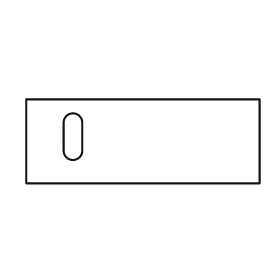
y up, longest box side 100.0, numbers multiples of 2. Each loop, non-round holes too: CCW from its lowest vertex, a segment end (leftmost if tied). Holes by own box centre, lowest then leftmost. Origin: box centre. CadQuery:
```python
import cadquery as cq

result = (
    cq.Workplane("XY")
    .moveTo(-50.0, -18.0)
    .lineTo(50.0, -18.0)
    .lineTo(50.0, 18.0)
    .lineTo(-50.0, 18.0)
    .close()
    .moveTo(-34.0, -4.0)
    .threePointArc((-30.0, -8.0), (-26.0, -4.0))
    .lineTo(-26.0, 8.0)
    .threePointArc((-30.0, 12.0), (-34.0, 8.0))
    .close()
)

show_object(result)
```